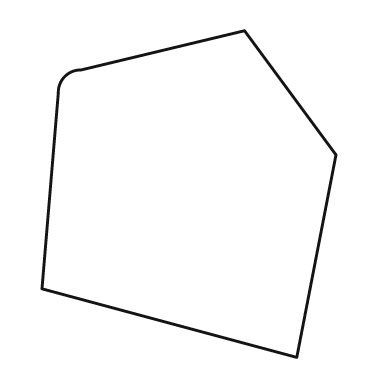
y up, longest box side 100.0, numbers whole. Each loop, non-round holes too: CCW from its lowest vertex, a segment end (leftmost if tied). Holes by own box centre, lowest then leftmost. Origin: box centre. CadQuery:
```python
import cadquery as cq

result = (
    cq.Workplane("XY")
    .moveTo(33.0, -50.0)
    .lineTo(45.0, 12.0)
    .lineTo(17.0, 50.0)
    .lineTo(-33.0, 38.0)
    .threePointArc((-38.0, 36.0), (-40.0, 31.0))
    .lineTo(-45.0, -29.0)
    .close()
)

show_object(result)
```